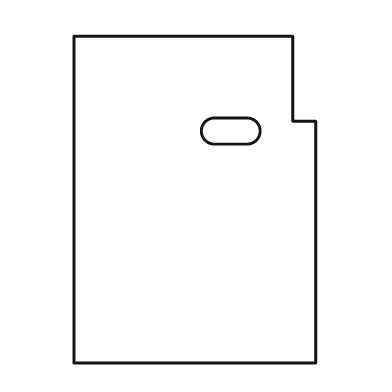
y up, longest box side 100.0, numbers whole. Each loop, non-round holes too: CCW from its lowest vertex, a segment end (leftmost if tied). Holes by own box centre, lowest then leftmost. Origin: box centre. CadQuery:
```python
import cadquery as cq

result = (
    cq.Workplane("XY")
    .moveTo(-37.0, -50.0)
    .lineTo(37.0, -50.0)
    .lineTo(37.0, 24.0)
    .lineTo(30.0, 24.0)
    .lineTo(30.0, 50.0)
    .lineTo(-37.0, 50.0)
    .close()
    .moveTo(6.0, 17.0)
    .lineTo(16.0, 17.0)
    .threePointArc((20.0, 21.0), (16.0, 25.0))
    .lineTo(6.0, 25.0)
    .threePointArc((2.0, 21.0), (6.0, 17.0))
    .close()
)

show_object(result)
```